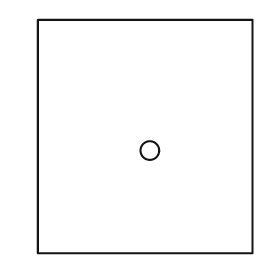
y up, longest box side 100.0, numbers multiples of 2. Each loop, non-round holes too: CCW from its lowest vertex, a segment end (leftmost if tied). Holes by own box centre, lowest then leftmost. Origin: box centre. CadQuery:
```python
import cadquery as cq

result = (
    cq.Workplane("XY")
    .moveTo(-46.0, -50.0)
    .lineTo(46.0, -50.0)
    .lineTo(46.0, 50.0)
    .lineTo(-46.0, 50.0)
    .close()
    .moveTo(2.0, -6.0)
    .circle(4.0)
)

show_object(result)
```